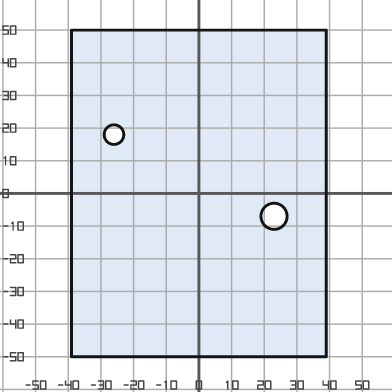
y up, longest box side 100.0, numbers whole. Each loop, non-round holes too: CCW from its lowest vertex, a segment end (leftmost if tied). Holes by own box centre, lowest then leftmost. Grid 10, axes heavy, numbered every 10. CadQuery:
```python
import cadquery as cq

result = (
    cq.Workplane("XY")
    .moveTo(-39.0, -50.0)
    .lineTo(39.0, -50.0)
    .lineTo(39.0, 50.0)
    .lineTo(-39.0, 50.0)
    .close()
    .moveTo(23.0, -7.0)
    .circle(4.0)
    .moveTo(-26.0, 18.0)
    .circle(3.0)
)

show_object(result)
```